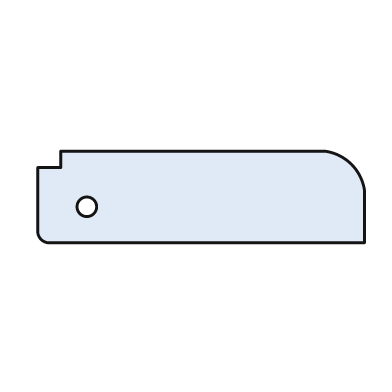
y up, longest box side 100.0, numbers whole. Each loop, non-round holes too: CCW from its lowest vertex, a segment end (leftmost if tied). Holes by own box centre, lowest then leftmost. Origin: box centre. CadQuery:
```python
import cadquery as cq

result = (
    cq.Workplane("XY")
    .moveTo(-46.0, -14.0)
    .lineTo(50.0, -14.0)
    .lineTo(50.0, 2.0)
    .threePointArc((46.0, 10.0), (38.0, 14.0))
    .lineTo(-43.0, 14.0)
    .lineTo(-43.0, 9.0)
    .lineTo(-50.0, 9.0)
    .lineTo(-50.0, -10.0)
    .threePointArc((-49.0, -13.0), (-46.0, -14.0))
    .close()
    .moveTo(-35.0, -3.0)
    .circle(3.0)
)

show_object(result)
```